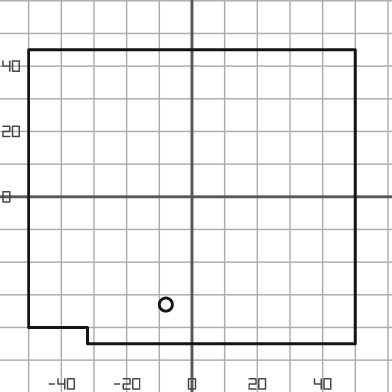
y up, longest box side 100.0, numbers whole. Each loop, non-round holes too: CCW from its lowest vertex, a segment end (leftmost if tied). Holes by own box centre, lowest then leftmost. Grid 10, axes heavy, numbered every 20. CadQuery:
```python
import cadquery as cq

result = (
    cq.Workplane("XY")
    .moveTo(-32.0, -45.0)
    .lineTo(50.0, -45.0)
    .lineTo(50.0, 45.0)
    .lineTo(-50.0, 45.0)
    .lineTo(-50.0, -40.0)
    .lineTo(-32.0, -40.0)
    .close()
    .moveTo(-8.0, -33.0)
    .circle(2.0)
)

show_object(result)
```